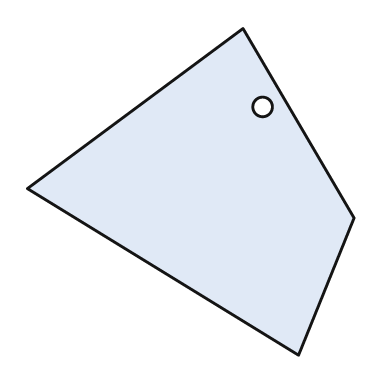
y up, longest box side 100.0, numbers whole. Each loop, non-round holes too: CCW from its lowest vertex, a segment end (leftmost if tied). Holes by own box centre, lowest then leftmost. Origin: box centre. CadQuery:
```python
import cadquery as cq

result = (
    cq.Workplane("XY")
    .moveTo(33.0, -50.0)
    .lineTo(50.0, -8.0)
    .lineTo(16.0, 50.0)
    .lineTo(-50.0, 1.0)
    .close()
    .moveTo(22.0, 26.0)
    .circle(3.0)
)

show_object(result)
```